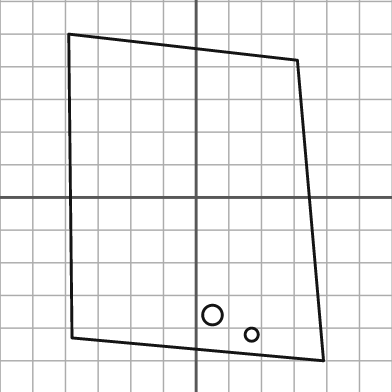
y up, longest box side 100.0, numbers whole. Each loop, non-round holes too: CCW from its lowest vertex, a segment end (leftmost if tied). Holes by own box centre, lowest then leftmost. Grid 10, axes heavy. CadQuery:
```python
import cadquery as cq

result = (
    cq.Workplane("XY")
    .moveTo(39.0, -50.0)
    .lineTo(31.0, 42.0)
    .lineTo(-39.0, 50.0)
    .lineTo(-38.0, -43.0)
    .close()
    .moveTo(17.0, -42.0)
    .circle(2.0)
    .moveTo(5.0, -36.0)
    .circle(3.0)
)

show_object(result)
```